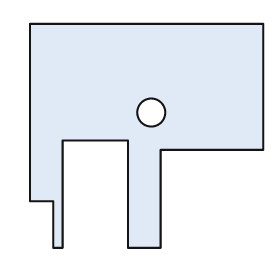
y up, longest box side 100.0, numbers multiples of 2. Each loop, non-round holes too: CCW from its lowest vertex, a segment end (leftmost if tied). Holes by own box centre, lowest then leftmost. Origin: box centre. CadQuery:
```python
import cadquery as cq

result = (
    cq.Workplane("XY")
    .moveTo(-40.0, -48.0)
    .lineTo(-36.0, -48.0)
    .lineTo(-36.0, -2.0)
    .lineTo(-8.0, -2.0)
    .lineTo(-8.0, -48.0)
    .lineTo(6.0, -48.0)
    .lineTo(6.0, -6.0)
    .lineTo(50.0, -6.0)
    .lineTo(50.0, 48.0)
    .lineTo(-50.0, 48.0)
    .lineTo(-50.0, -28.0)
    .lineTo(-40.0, -28.0)
    .close()
    .moveTo(2.0, 10.0)
    .circle(6.0)
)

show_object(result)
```